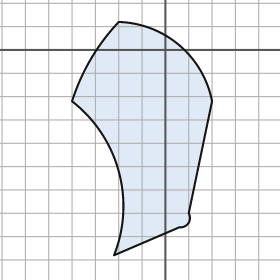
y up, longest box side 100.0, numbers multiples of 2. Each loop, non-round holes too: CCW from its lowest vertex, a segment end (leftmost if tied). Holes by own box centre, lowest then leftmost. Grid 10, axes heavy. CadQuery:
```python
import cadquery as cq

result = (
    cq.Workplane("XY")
    .moveTo(-22.0, -88.0)
    .lineTo(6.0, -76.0)
    .threePointArc((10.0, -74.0), (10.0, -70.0))
    .lineTo(20.0, -22.0)
    .threePointArc((6.0, 2.0), (-20.0, 12.0))
    .threePointArc((-32.0, -4.0), (-40.0, -22.0))
    .threePointArc((-20.0, -52.0), (-22.0, -88.0))
    .close()
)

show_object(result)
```